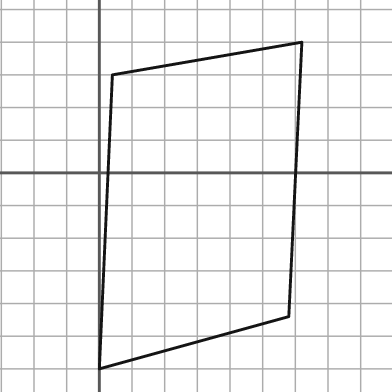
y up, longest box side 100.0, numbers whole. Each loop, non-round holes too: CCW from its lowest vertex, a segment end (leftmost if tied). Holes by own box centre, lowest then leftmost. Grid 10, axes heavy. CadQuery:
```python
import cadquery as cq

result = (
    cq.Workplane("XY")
    .moveTo(0.0, -60.0)
    .lineTo(58.0, -44.0)
    .lineTo(62.0, 40.0)
    .lineTo(4.0, 30.0)
    .close()
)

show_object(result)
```